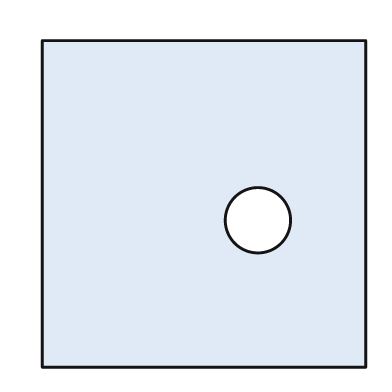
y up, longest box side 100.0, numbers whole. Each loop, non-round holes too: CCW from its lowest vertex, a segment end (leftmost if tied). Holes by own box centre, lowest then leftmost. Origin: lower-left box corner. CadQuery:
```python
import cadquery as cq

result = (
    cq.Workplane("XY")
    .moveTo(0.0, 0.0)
    .lineTo(99.0, 0.0)
    .lineTo(99.0, 100.0)
    .lineTo(0.0, 100.0)
    .close()
    .moveTo(66.0, 45.0)
    .circle(10.0)
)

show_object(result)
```